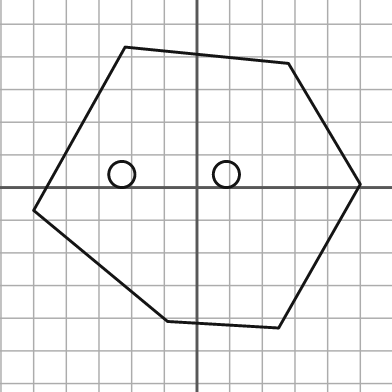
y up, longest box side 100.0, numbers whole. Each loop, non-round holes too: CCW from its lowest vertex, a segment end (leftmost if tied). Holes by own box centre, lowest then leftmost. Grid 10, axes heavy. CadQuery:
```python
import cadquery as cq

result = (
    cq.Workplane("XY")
    .moveTo(25.0, -43.0)
    .lineTo(50.0, 1.0)
    .lineTo(28.0, 38.0)
    .lineTo(-22.0, 43.0)
    .lineTo(-50.0, -7.0)
    .lineTo(-9.0, -41.0)
    .close()
    .moveTo(-23.0, 4.0)
    .circle(4.0)
    .moveTo(9.0, 4.0)
    .circle(4.0)
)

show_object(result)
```